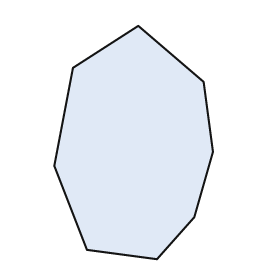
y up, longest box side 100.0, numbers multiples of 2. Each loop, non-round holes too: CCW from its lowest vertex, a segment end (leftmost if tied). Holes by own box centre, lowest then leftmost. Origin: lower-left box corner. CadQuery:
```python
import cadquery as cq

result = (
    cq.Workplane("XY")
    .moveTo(44.0, 0.0)
    .lineTo(60.0, 18.0)
    .lineTo(68.0, 46.0)
    .lineTo(64.0, 76.0)
    .lineTo(36.0, 100.0)
    .lineTo(8.0, 82.0)
    .lineTo(0.0, 40.0)
    .lineTo(14.0, 4.0)
    .close()
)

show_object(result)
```